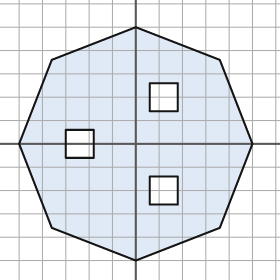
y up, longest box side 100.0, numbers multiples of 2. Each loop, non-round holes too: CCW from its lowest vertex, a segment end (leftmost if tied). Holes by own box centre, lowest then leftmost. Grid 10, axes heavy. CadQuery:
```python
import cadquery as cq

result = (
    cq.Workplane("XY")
    .moveTo(0.0, -50.0)
    .lineTo(36.0, -36.0)
    .lineTo(50.0, 0.0)
    .lineTo(36.0, 36.0)
    .lineTo(0.0, 50.0)
    .lineTo(-36.0, 36.0)
    .lineTo(-50.0, 0.0)
    .lineTo(-36.0, -36.0)
    .close()
    .moveTo(6.0, -26.0)
    .lineTo(18.0, -26.0)
    .lineTo(18.0, -14.0)
    .lineTo(6.0, -14.0)
    .close()
    .moveTo(-30.0, -6.0)
    .lineTo(-18.0, -6.0)
    .lineTo(-18.0, 6.0)
    .lineTo(-30.0, 6.0)
    .close()
    .moveTo(6.0, 14.0)
    .lineTo(18.0, 14.0)
    .lineTo(18.0, 26.0)
    .lineTo(6.0, 26.0)
    .close()
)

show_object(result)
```